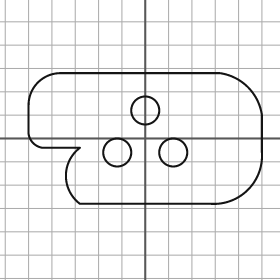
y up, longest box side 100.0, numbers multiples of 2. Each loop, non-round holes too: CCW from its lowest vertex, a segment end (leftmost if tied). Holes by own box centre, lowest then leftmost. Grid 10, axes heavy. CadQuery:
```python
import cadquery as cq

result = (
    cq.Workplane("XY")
    .moveTo(-28.0, -28.0)
    .lineTo(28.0, -28.0)
    .threePointArc((44.0, -22.0), (50.0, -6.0))
    .lineTo(50.0, 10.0)
    .threePointArc((44.0, 22.0), (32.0, 28.0))
    .lineTo(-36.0, 28.0)
    .threePointArc((-46.0, 24.0), (-50.0, 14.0))
    .lineTo(-50.0, 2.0)
    .threePointArc((-48.0, -2.0), (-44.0, -4.0))
    .lineTo(-28.0, -4.0)
    .threePointArc((-34.0, -16.0), (-28.0, -28.0))
    .close()
    .moveTo(-12.0, -6.0)
    .circle(6.0)
    .moveTo(12.0, -6.0)
    .circle(6.0)
    .moveTo(0.0, 12.0)
    .circle(6.0)
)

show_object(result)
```